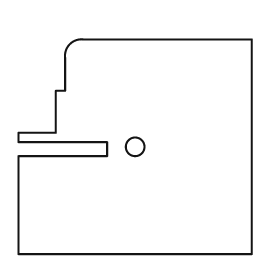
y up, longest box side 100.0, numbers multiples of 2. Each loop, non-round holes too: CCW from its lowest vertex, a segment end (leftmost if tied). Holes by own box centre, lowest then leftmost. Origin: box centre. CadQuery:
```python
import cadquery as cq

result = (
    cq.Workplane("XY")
    .moveTo(-50.0, -46.0)
    .lineTo(50.0, -46.0)
    .lineTo(50.0, 46.0)
    .lineTo(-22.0, 46.0)
    .threePointArc((-28.0, 44.0), (-30.0, 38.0))
    .lineTo(-30.0, 24.0)
    .lineTo(-34.0, 24.0)
    .lineTo(-34.0, 6.0)
    .lineTo(-50.0, 6.0)
    .lineTo(-50.0, 2.0)
    .lineTo(-12.0, 2.0)
    .lineTo(-12.0, -4.0)
    .lineTo(-50.0, -4.0)
    .close()
    .moveTo(0.0, 0.0)
    .circle(4.0)
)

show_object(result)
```